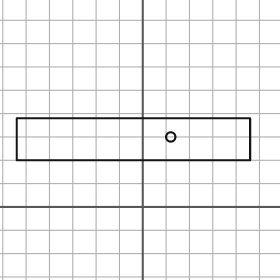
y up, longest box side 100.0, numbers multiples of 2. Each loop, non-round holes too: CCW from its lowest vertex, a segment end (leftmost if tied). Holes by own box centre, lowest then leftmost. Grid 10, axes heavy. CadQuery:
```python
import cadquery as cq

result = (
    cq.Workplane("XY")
    .moveTo(-54.0, 20.0)
    .lineTo(46.0, 20.0)
    .lineTo(46.0, 38.0)
    .lineTo(-54.0, 38.0)
    .close()
    .moveTo(12.0, 30.0)
    .circle(2.0)
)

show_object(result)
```